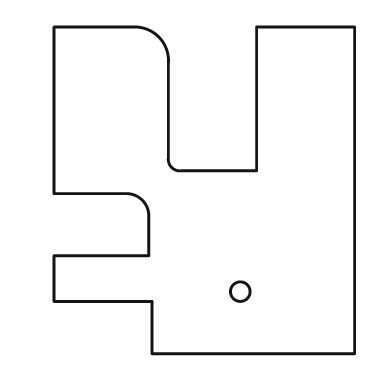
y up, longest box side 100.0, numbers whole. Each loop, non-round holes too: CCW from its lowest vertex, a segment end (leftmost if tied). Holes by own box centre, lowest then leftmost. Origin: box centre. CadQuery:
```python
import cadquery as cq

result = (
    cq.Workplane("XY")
    .moveTo(-16.0, -50.0)
    .lineTo(46.0, -50.0)
    .lineTo(46.0, 50.0)
    .lineTo(16.0, 50.0)
    .lineTo(16.0, 6.0)
    .lineTo(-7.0, 6.0)
    .threePointArc((-10.0, 7.0), (-11.0, 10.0))
    .lineTo(-11.0, 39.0)
    .threePointArc((-14.0, 47.0), (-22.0, 50.0))
    .lineTo(-46.0, 50.0)
    .lineTo(-46.0, -1.0)
    .lineTo(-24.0, -1.0)
    .threePointArc((-19.0, -3.0), (-17.0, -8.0))
    .lineTo(-17.0, -20.0)
    .lineTo(-46.0, -20.0)
    .lineTo(-46.0, -34.0)
    .lineTo(-16.0, -34.0)
    .close()
    .moveTo(11.0, -31.0)
    .circle(3.0)
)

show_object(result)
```